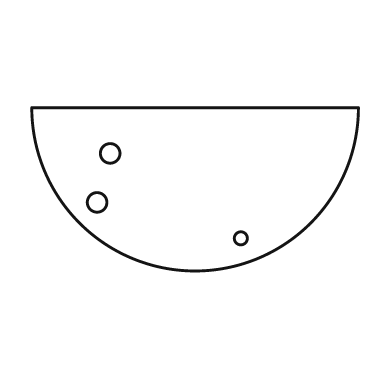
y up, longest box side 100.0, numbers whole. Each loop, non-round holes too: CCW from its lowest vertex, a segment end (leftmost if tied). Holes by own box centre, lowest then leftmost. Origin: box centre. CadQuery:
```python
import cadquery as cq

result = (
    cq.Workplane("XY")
    .moveTo(-50.0, 25.0)
    .threePointArc((0.0, -25.0), (50.0, 25.0))
    .close()
    .moveTo(14.0, -15.0)
    .circle(2.0)
    .moveTo(-30.0, -4.0)
    .circle(3.0)
    .moveTo(-26.0, 11.0)
    .circle(3.0)
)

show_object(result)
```